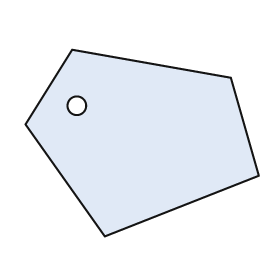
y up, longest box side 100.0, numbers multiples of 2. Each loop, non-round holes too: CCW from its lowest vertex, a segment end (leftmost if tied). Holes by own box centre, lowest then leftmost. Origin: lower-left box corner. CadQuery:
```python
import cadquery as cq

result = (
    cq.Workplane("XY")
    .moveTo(34.0, 0.0)
    .lineTo(100.0, 26.0)
    .lineTo(88.0, 68.0)
    .lineTo(20.0, 80.0)
    .lineTo(0.0, 48.0)
    .close()
    .moveTo(22.0, 56.0)
    .circle(4.0)
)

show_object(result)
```